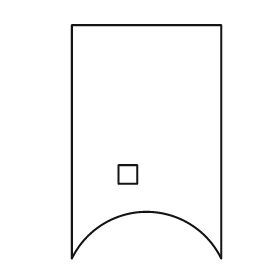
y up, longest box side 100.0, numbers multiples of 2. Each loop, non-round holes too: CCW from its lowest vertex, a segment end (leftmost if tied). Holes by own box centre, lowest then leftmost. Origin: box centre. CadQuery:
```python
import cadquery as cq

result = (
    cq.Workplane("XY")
    .moveTo(-32.0, -50.0)
    .threePointArc((0.0, -30.0), (32.0, -50.0))
    .lineTo(32.0, 50.0)
    .lineTo(-32.0, 50.0)
    .close()
    .moveTo(-12.0, -18.0)
    .lineTo(-4.0, -18.0)
    .lineTo(-4.0, -10.0)
    .lineTo(-12.0, -10.0)
    .close()
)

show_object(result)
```